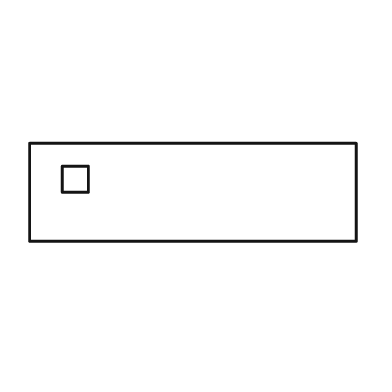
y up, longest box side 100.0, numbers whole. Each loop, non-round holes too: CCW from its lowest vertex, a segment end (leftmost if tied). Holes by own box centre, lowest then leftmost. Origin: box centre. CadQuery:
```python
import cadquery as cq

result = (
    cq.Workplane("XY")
    .moveTo(-50.0, -15.0)
    .lineTo(50.0, -15.0)
    .lineTo(50.0, 15.0)
    .lineTo(-50.0, 15.0)
    .close()
    .moveTo(-40.0, 0.0)
    .lineTo(-32.0, 0.0)
    .lineTo(-32.0, 8.0)
    .lineTo(-40.0, 8.0)
    .close()
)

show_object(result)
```